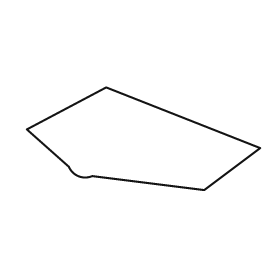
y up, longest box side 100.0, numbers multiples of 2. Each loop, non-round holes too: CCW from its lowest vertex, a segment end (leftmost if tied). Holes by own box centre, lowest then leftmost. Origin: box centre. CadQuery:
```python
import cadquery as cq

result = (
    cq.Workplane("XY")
    .moveTo(26.0, -22.0)
    .lineTo(50.0, -4.0)
    .lineTo(-16.0, 22.0)
    .lineTo(-50.0, 4.0)
    .lineTo(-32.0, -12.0)
    .threePointArc((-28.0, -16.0), (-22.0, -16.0))
    .close()
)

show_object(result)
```